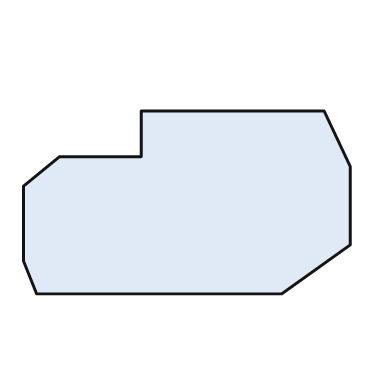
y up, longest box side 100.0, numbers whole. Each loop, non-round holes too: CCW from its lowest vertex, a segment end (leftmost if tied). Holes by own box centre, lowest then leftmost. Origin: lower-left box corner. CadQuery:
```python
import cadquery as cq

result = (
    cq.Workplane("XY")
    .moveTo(4.0, 0.0)
    .lineTo(79.0, 0.0)
    .lineTo(100.0, 15.0)
    .lineTo(100.0, 39.0)
    .lineTo(92.0, 56.0)
    .lineTo(36.0, 56.0)
    .lineTo(36.0, 42.0)
    .lineTo(11.0, 42.0)
    .lineTo(0.0, 33.0)
    .lineTo(0.0, 10.0)
    .close()
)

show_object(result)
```